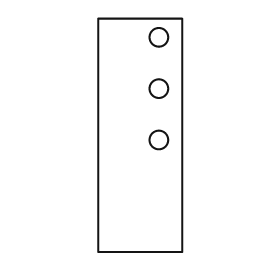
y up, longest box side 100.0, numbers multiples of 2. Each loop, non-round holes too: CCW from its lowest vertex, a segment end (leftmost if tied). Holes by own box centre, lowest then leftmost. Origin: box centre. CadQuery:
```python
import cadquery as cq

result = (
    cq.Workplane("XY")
    .moveTo(-18.0, -50.0)
    .lineTo(18.0, -50.0)
    .lineTo(18.0, 50.0)
    .lineTo(-18.0, 50.0)
    .close()
    .moveTo(8.0, -2.0)
    .circle(4.0)
    .moveTo(8.0, 20.0)
    .circle(4.0)
    .moveTo(8.0, 42.0)
    .circle(4.0)
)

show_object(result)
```